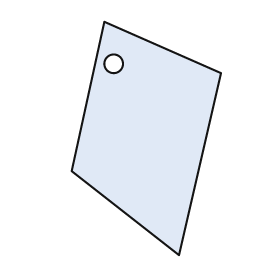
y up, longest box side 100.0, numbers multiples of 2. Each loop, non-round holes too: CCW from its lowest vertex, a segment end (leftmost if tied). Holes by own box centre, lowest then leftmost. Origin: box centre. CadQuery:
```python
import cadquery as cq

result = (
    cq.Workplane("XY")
    .moveTo(14.0, -50.0)
    .lineTo(32.0, 28.0)
    .lineTo(-18.0, 50.0)
    .lineTo(-32.0, -14.0)
    .close()
    .moveTo(-14.0, 32.0)
    .circle(4.0)
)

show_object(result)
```